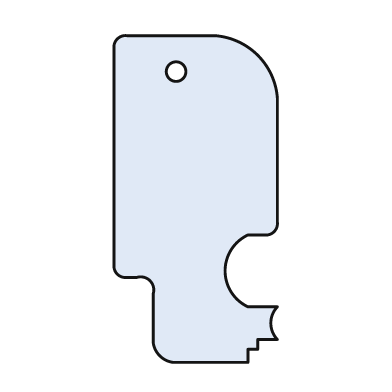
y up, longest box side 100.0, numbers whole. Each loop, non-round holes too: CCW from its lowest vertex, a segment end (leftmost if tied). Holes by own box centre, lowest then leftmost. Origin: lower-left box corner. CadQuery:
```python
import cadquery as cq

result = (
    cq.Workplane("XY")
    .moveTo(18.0, 0.0)
    .lineTo(41.0, 0.0)
    .lineTo(41.0, 4.0)
    .lineTo(44.0, 4.0)
    .lineTo(44.0, 7.0)
    .lineTo(50.0, 7.0)
    .threePointArc((48.0, 12.0), (50.0, 17.0))
    .lineTo(41.0, 17.0)
    .threePointArc((34.0, 28.0), (41.0, 39.0))
    .lineTo(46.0, 39.0)
    .threePointArc((49.0, 40.0), (50.0, 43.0))
    .lineTo(50.0, 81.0)
    .threePointArc((44.0, 94.0), (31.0, 100.0))
    .lineTo(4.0, 100.0)
    .threePointArc((1.0, 99.0), (0.0, 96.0))
    .lineTo(0.0, 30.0)
    .threePointArc((1.0, 27.0), (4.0, 26.0))
    .lineTo(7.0, 26.0)
    .threePointArc((11.0, 25.0), (12.0, 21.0))
    .lineTo(12.0, 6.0)
    .threePointArc((14.0, 2.0), (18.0, 0.0))
    .close()
    .moveTo(19.0, 89.0)
    .circle(3.0)
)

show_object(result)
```